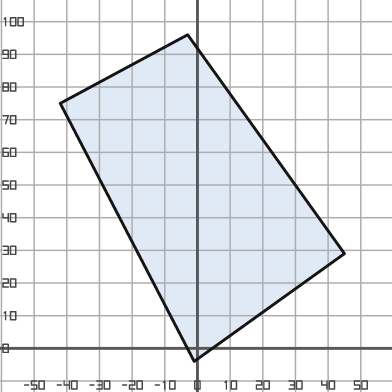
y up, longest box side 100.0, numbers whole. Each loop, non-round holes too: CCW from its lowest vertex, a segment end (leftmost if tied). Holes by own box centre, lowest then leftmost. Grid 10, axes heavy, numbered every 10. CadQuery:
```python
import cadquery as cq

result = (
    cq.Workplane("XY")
    .moveTo(-1.0, -4.0)
    .lineTo(45.0, 29.0)
    .lineTo(-3.0, 96.0)
    .lineTo(-42.0, 75.0)
    .close()
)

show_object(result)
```